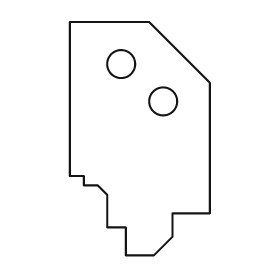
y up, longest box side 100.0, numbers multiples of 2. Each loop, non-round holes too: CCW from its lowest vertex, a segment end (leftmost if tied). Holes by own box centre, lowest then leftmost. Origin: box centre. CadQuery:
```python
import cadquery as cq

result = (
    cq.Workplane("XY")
    .moveTo(-6.0, -50.0)
    .lineTo(6.0, -50.0)
    .lineTo(14.0, -42.0)
    .lineTo(14.0, -32.0)
    .lineTo(30.0, -32.0)
    .lineTo(30.0, 24.0)
    .lineTo(4.0, 50.0)
    .lineTo(-30.0, 50.0)
    .lineTo(-30.0, -16.0)
    .lineTo(-24.0, -16.0)
    .lineTo(-24.0, -20.0)
    .lineTo(-18.0, -20.0)
    .lineTo(-14.0, -24.0)
    .lineTo(-14.0, -38.0)
    .lineTo(-6.0, -38.0)
    .close()
    .moveTo(10.0, 16.0)
    .circle(6.0)
    .moveTo(-8.0, 32.0)
    .circle(6.0)
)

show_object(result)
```